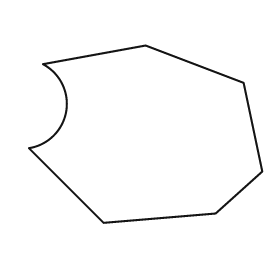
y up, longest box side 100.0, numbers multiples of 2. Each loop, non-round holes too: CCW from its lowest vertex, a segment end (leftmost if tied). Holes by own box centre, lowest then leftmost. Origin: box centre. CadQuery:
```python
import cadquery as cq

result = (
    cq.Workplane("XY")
    .moveTo(-18.0, -38.0)
    .lineTo(30.0, -34.0)
    .lineTo(50.0, -16.0)
    .lineTo(42.0, 22.0)
    .lineTo(0.0, 38.0)
    .lineTo(-44.0, 30.0)
    .threePointArc((-34.0, 10.0), (-50.0, -6.0))
    .close()
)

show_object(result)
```